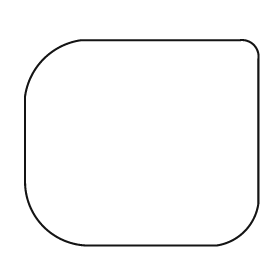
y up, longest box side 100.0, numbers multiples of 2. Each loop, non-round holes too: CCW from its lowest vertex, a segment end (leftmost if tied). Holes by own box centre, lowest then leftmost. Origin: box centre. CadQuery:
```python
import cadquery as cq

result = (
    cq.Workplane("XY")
    .moveTo(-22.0, -44.0)
    .lineTo(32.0, -44.0)
    .threePointArc((44.0, -38.0), (50.0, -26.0))
    .lineTo(50.0, 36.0)
    .threePointArc((48.0, 42.0), (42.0, 44.0))
    .lineTo(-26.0, 44.0)
    .threePointArc((-42.0, 36.0), (-50.0, 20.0))
    .lineTo(-50.0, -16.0)
    .threePointArc((-42.0, -36.0), (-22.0, -44.0))
    .close()
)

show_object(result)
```